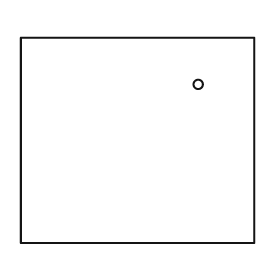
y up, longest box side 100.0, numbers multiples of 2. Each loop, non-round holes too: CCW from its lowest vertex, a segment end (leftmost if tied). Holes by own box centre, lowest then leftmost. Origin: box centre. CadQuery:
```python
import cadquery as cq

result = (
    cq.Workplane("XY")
    .moveTo(-50.0, -44.0)
    .lineTo(50.0, -44.0)
    .lineTo(50.0, 44.0)
    .lineTo(-50.0, 44.0)
    .close()
    .moveTo(26.0, 24.0)
    .circle(2.0)
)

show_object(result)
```